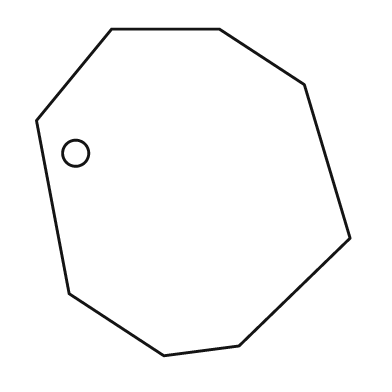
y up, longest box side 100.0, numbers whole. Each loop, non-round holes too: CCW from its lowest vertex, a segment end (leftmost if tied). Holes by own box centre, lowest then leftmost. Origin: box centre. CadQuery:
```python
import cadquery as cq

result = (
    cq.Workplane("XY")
    .moveTo(-9.0, -50.0)
    .lineTo(14.0, -47.0)
    .lineTo(48.0, -14.0)
    .lineTo(34.0, 33.0)
    .lineTo(8.0, 50.0)
    .lineTo(-25.0, 50.0)
    .lineTo(-48.0, 22.0)
    .lineTo(-38.0, -31.0)
    .close()
    .moveTo(-36.0, 12.0)
    .circle(4.0)
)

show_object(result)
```